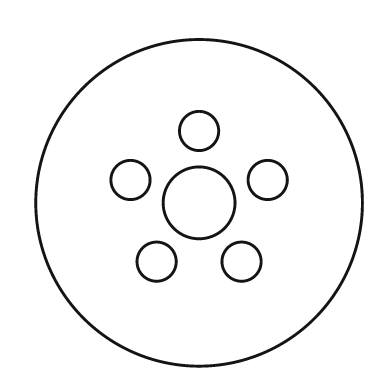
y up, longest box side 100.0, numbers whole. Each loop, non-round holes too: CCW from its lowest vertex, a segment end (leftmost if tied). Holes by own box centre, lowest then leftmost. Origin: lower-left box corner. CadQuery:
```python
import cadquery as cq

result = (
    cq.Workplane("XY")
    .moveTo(50.0, 50.0)
    .circle(50.0)
    .moveTo(37.0, 32.0)
    .circle(6.0)
    .moveTo(63.0, 32.0)
    .circle(6.0)
    .moveTo(50.0, 50.0)
    .circle(11.0)
    .moveTo(29.0, 57.0)
    .circle(6.0)
    .moveTo(71.0, 57.0)
    .circle(6.0)
    .moveTo(50.0, 72.0)
    .circle(6.0)
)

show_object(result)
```